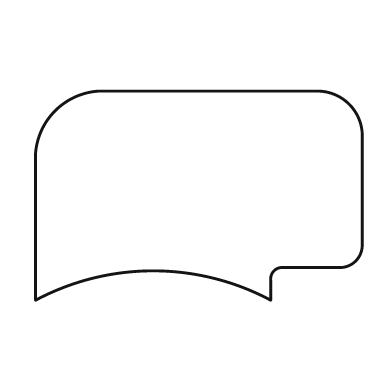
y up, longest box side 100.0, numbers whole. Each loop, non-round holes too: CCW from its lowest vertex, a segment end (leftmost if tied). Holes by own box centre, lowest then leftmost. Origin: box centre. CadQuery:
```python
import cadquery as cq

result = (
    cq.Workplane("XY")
    .moveTo(-50.0, -32.0)
    .threePointArc((-14.0, -23.0), (22.0, -32.0))
    .lineTo(22.0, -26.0)
    .threePointArc((23.0, -23.0), (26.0, -22.0))
    .lineTo(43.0, -22.0)
    .threePointArc((48.0, -20.0), (50.0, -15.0))
    .lineTo(50.0, 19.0)
    .threePointArc((46.0, 28.0), (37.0, 32.0))
    .lineTo(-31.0, 32.0)
    .threePointArc((-44.0, 26.0), (-50.0, 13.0))
    .close()
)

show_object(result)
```